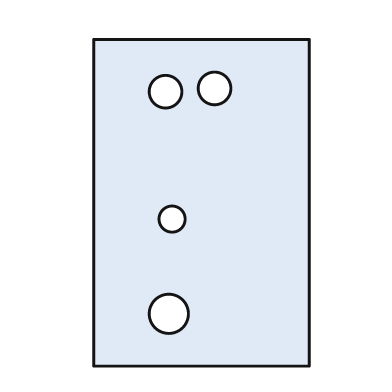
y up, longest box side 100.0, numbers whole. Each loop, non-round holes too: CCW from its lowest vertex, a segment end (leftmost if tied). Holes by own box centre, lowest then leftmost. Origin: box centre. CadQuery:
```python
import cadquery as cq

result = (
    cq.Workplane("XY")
    .moveTo(-33.0, -50.0)
    .lineTo(33.0, -50.0)
    .lineTo(33.0, 50.0)
    .lineTo(-33.0, 50.0)
    .close()
    .moveTo(-10.0, -34.0)
    .circle(6.0)
    .moveTo(-9.0, -5.0)
    .circle(4.0)
    .moveTo(-11.0, 34.0)
    .circle(5.0)
    .moveTo(4.0, 35.0)
    .circle(5.0)
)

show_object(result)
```